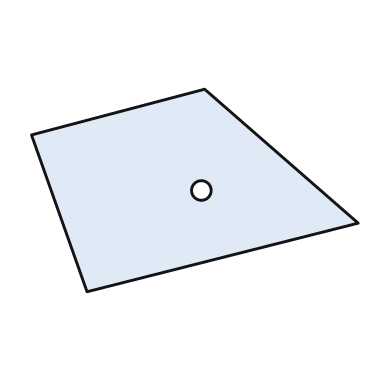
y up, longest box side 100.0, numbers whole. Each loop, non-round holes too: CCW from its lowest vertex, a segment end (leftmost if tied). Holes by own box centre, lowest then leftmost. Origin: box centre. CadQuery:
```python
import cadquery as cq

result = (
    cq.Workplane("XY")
    .moveTo(-33.0, -31.0)
    .lineTo(50.0, -10.0)
    .lineTo(3.0, 31.0)
    .lineTo(-50.0, 17.0)
    .close()
    .moveTo(2.0, 0.0)
    .circle(3.0)
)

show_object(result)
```